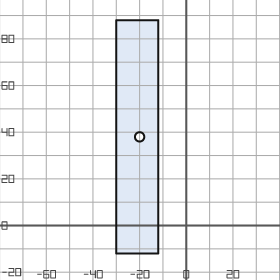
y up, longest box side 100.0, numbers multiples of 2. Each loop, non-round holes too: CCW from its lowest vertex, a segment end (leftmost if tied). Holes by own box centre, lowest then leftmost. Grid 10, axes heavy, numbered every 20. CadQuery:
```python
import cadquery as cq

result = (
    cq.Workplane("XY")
    .moveTo(-30.0, -12.0)
    .lineTo(-12.0, -12.0)
    .lineTo(-12.0, 88.0)
    .lineTo(-30.0, 88.0)
    .close()
    .moveTo(-20.0, 38.0)
    .circle(2.0)
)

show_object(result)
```